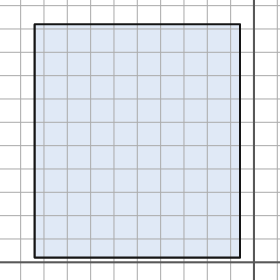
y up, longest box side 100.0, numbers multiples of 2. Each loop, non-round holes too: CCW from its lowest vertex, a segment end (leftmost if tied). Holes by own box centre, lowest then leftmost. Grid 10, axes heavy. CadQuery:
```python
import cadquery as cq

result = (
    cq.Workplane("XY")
    .moveTo(-94.0, 2.0)
    .lineTo(-6.0, 2.0)
    .lineTo(-6.0, 102.0)
    .lineTo(-94.0, 102.0)
    .close()
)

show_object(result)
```